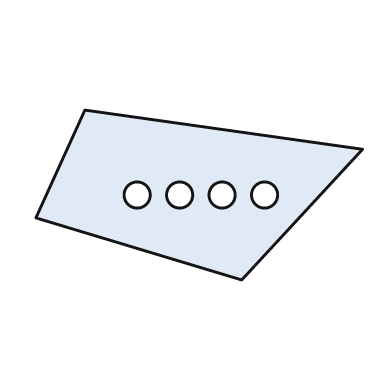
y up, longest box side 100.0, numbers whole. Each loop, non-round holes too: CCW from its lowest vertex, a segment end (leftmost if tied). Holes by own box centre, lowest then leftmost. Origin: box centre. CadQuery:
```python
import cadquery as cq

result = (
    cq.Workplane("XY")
    .moveTo(13.0, -26.0)
    .lineTo(50.0, 14.0)
    .lineTo(-35.0, 26.0)
    .lineTo(-50.0, -7.0)
    .close()
    .moveTo(-19.0, 0.0)
    .circle(4.0)
    .moveTo(-6.0, 0.0)
    .circle(4.0)
    .moveTo(7.0, 0.0)
    .circle(4.0)
    .moveTo(20.0, 0.0)
    .circle(4.0)
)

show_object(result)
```